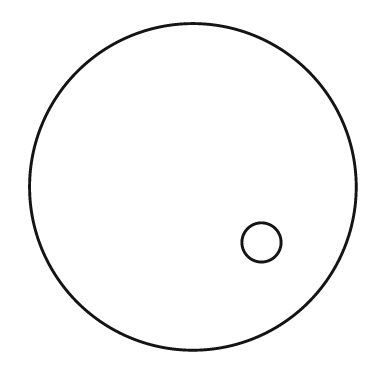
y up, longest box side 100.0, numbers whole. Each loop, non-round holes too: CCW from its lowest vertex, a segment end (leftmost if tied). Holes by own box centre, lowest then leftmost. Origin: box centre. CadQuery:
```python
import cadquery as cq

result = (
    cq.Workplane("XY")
    .moveTo(0.0, 0.0)
    .circle(50.0)
    .moveTo(21.0, -17.0)
    .circle(6.0)
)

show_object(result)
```